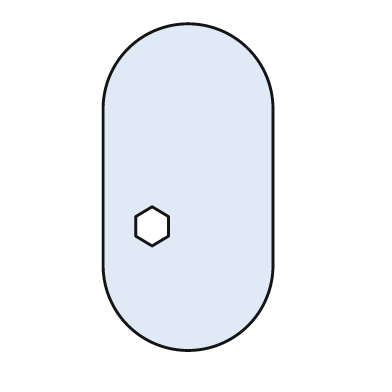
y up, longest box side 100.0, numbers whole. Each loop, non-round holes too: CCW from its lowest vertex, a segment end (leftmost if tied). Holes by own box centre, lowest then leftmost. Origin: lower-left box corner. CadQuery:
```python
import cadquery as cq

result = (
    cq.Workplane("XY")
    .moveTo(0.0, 26.0)
    .threePointArc((26.0, 0.0), (52.0, 26.0))
    .lineTo(52.0, 74.0)
    .threePointArc((26.0, 100.0), (0.0, 74.0))
    .close()
    .moveTo(15.0, 32.0)
    .lineTo(20.0, 35.0)
    .lineTo(20.0, 41.0)
    .lineTo(15.0, 44.0)
    .lineTo(10.0, 41.0)
    .lineTo(10.0, 35.0)
    .close()
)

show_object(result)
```